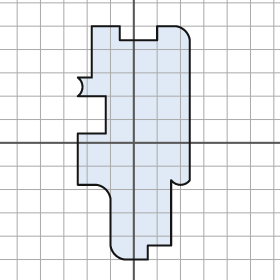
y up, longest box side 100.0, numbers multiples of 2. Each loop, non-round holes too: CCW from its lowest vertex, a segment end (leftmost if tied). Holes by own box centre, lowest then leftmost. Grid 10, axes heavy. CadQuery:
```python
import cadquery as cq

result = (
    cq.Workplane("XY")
    .moveTo(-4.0, -50.0)
    .lineTo(6.0, -50.0)
    .lineTo(6.0, -44.0)
    .lineTo(16.0, -44.0)
    .lineTo(16.0, -16.0)
    .threePointArc((20.0, -18.0), (24.0, -16.0))
    .lineTo(24.0, 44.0)
    .threePointArc((22.0, 48.0), (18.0, 50.0))
    .lineTo(10.0, 50.0)
    .lineTo(10.0, 44.0)
    .lineTo(-6.0, 44.0)
    .lineTo(-6.0, 50.0)
    .lineTo(-18.0, 50.0)
    .lineTo(-18.0, 28.0)
    .lineTo(-24.0, 28.0)
    .threePointArc((-22.0, 24.0), (-24.0, 20.0))
    .lineTo(-12.0, 20.0)
    .lineTo(-12.0, 4.0)
    .lineTo(-24.0, 4.0)
    .lineTo(-24.0, -18.0)
    .lineTo(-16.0, -18.0)
    .threePointArc((-12.0, -20.0), (-10.0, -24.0))
    .lineTo(-10.0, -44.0)
    .threePointArc((-8.0, -48.0), (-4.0, -50.0))
    .close()
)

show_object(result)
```